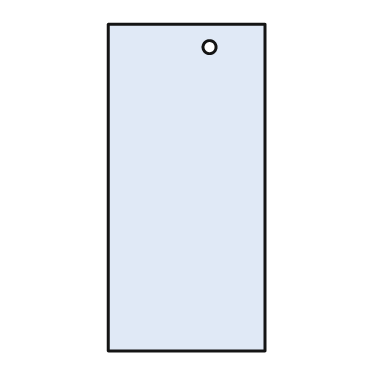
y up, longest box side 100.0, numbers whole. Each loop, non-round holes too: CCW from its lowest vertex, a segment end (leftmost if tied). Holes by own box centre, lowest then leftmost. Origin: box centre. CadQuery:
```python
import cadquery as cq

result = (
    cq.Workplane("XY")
    .moveTo(-24.0, -50.0)
    .lineTo(24.0, -50.0)
    .lineTo(24.0, 50.0)
    .lineTo(-24.0, 50.0)
    .close()
    .moveTo(7.0, 43.0)
    .circle(2.0)
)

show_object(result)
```